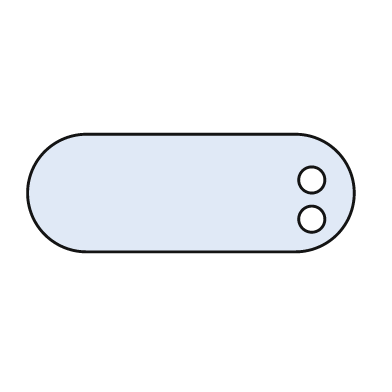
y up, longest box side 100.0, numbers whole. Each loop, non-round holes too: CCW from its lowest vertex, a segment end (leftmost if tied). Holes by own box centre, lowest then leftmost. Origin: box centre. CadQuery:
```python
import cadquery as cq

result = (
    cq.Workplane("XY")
    .moveTo(-32.0, -18.0)
    .lineTo(32.0, -18.0)
    .threePointArc((50.0, 0.0), (32.0, 18.0))
    .lineTo(-32.0, 18.0)
    .threePointArc((-50.0, 0.0), (-32.0, -18.0))
    .close()
    .moveTo(37.0, -8.0)
    .circle(4.0)
    .moveTo(37.0, 4.0)
    .circle(4.0)
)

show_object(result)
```